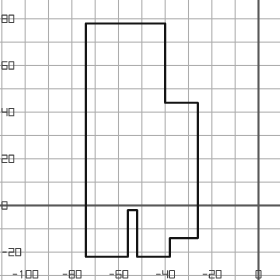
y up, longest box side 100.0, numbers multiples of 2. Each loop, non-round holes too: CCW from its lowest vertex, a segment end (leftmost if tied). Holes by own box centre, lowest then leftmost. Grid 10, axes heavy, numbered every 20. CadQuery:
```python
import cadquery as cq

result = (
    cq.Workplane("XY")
    .moveTo(-74.0, -22.0)
    .lineTo(-56.0, -22.0)
    .lineTo(-56.0, -2.0)
    .lineTo(-52.0, -2.0)
    .lineTo(-52.0, -22.0)
    .lineTo(-38.0, -22.0)
    .lineTo(-38.0, -14.0)
    .lineTo(-26.0, -14.0)
    .lineTo(-26.0, 44.0)
    .lineTo(-40.0, 44.0)
    .lineTo(-40.0, 78.0)
    .lineTo(-74.0, 78.0)
    .close()
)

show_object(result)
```